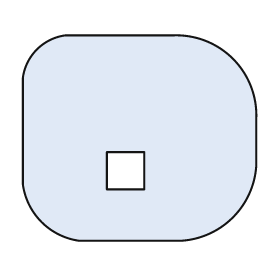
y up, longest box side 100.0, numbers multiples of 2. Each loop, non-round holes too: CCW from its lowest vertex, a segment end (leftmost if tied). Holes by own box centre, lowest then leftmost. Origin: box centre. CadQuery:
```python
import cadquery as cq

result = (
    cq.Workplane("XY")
    .moveTo(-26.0, -44.0)
    .lineTo(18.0, -44.0)
    .threePointArc((40.0, -34.0), (50.0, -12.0))
    .lineTo(50.0, 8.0)
    .threePointArc((40.0, 34.0), (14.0, 44.0))
    .lineTo(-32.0, 44.0)
    .threePointArc((-44.0, 38.0), (-50.0, 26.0))
    .lineTo(-50.0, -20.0)
    .threePointArc((-42.0, -36.0), (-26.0, -44.0))
    .close()
    .moveTo(-14.0, -22.0)
    .lineTo(2.0, -22.0)
    .lineTo(2.0, -6.0)
    .lineTo(-14.0, -6.0)
    .close()
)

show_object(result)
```